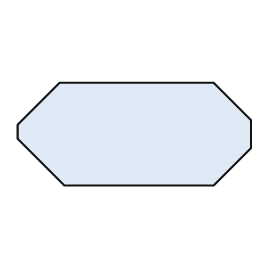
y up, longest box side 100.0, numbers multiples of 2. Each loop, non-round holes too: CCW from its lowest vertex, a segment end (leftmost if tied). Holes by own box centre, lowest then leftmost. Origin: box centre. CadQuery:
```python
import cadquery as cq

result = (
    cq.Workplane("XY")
    .moveTo(-30.0, -22.0)
    .lineTo(34.0, -22.0)
    .lineTo(50.0, -6.0)
    .lineTo(50.0, 6.0)
    .lineTo(34.0, 22.0)
    .lineTo(-32.0, 22.0)
    .lineTo(-50.0, 4.0)
    .lineTo(-50.0, -2.0)
    .close()
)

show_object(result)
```